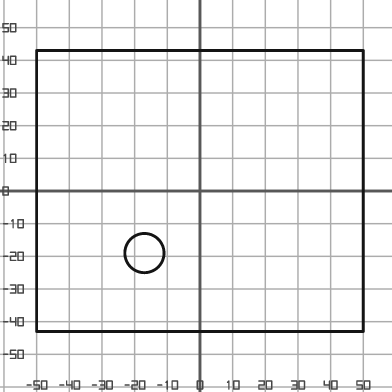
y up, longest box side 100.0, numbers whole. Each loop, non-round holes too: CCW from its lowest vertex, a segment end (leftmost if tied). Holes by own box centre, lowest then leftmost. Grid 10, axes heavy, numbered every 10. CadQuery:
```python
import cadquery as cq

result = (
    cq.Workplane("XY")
    .moveTo(-50.0, -43.0)
    .lineTo(50.0, -43.0)
    .lineTo(50.0, 43.0)
    .lineTo(-50.0, 43.0)
    .close()
    .moveTo(-17.0, -19.0)
    .circle(6.0)
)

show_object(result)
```